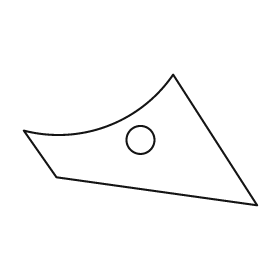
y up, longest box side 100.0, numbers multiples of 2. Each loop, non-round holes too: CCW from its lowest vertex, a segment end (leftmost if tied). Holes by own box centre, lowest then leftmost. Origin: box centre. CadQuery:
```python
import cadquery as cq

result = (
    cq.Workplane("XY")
    .moveTo(50.0, -28.0)
    .lineTo(14.0, 28.0)
    .threePointArc((-14.0, 6.0), (-50.0, 4.0))
    .lineTo(-36.0, -16.0)
    .close()
    .moveTo(0.0, 0.0)
    .circle(6.0)
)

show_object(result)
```